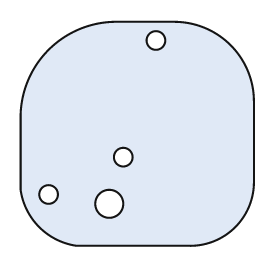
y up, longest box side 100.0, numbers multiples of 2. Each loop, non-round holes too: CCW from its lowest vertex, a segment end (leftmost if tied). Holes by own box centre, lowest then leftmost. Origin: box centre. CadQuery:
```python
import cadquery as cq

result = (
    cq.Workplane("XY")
    .moveTo(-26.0, -48.0)
    .lineTo(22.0, -48.0)
    .threePointArc((42.0, -40.0), (50.0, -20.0))
    .lineTo(50.0, 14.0)
    .threePointArc((40.0, 38.0), (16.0, 48.0))
    .lineTo(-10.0, 48.0)
    .threePointArc((-38.0, 36.0), (-50.0, 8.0))
    .lineTo(-50.0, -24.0)
    .threePointArc((-42.0, -40.0), (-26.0, -48.0))
    .close()
    .moveTo(-12.0, -30.0)
    .circle(6.0)
    .moveTo(-38.0, -26.0)
    .circle(4.0)
    .moveTo(-6.0, -10.0)
    .circle(4.0)
    .moveTo(8.0, 40.0)
    .circle(4.0)
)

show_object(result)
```